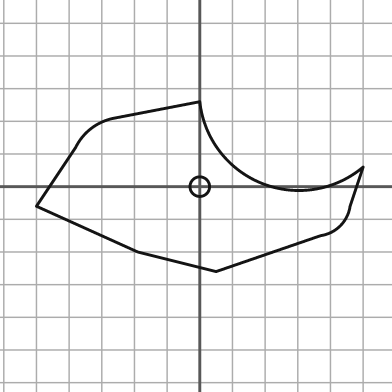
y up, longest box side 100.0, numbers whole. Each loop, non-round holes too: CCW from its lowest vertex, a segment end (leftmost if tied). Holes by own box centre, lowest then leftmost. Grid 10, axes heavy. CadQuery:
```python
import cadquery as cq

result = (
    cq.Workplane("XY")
    .moveTo(5.0, -26.0)
    .lineTo(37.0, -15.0)
    .threePointArc((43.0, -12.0), (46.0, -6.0))
    .lineTo(50.0, 6.0)
    .threePointArc((19.0, 1.0), (0.0, 26.0))
    .lineTo(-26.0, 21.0)
    .threePointArc((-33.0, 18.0), (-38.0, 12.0))
    .lineTo(-50.0, -6.0)
    .lineTo(-19.0, -20.0)
    .close()
    .moveTo(0.0, 0.0)
    .circle(3.0)
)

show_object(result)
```